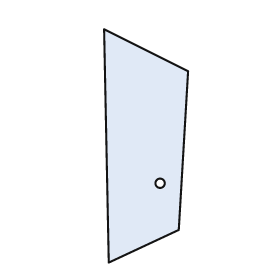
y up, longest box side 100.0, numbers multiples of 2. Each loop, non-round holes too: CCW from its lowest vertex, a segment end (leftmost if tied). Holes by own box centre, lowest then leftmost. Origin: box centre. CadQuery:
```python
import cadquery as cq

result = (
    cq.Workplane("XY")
    .moveTo(-16.0, -50.0)
    .lineTo(14.0, -36.0)
    .lineTo(18.0, 32.0)
    .lineTo(-18.0, 50.0)
    .close()
    .moveTo(6.0, -16.0)
    .circle(2.0)
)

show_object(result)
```